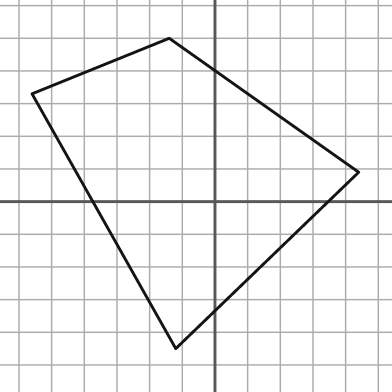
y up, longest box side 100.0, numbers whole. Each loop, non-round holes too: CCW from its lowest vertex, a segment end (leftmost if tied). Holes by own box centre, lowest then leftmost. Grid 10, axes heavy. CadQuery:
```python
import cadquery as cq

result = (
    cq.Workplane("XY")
    .moveTo(-12.0, -45.0)
    .lineTo(44.0, 9.0)
    .lineTo(-14.0, 50.0)
    .lineTo(-56.0, 33.0)
    .close()
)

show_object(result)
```